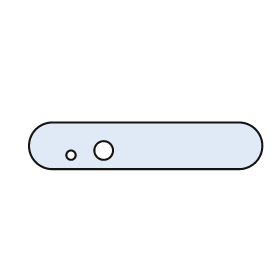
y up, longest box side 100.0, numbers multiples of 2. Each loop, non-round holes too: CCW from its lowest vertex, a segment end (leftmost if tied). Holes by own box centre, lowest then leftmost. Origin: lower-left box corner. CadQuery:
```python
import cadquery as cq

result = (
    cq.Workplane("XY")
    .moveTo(10.0, 0.0)
    .lineTo(90.0, 0.0)
    .threePointArc((100.0, 10.0), (90.0, 20.0))
    .lineTo(10.0, 20.0)
    .threePointArc((0.0, 10.0), (10.0, 0.0))
    .close()
    .moveTo(18.0, 6.0)
    .circle(2.0)
    .moveTo(32.0, 8.0)
    .circle(4.0)
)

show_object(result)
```